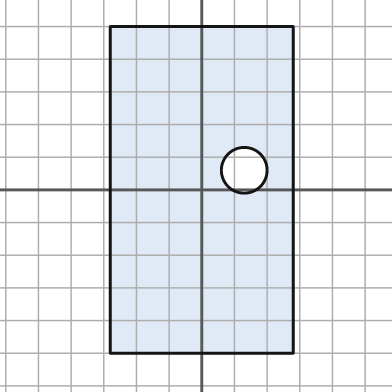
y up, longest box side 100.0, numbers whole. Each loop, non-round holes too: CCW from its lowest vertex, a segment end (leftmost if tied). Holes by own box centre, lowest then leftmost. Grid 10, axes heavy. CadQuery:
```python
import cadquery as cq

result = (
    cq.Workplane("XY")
    .moveTo(-28.0, -50.0)
    .lineTo(28.0, -50.0)
    .lineTo(28.0, 50.0)
    .lineTo(-28.0, 50.0)
    .close()
    .moveTo(13.0, 6.0)
    .circle(7.0)
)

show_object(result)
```